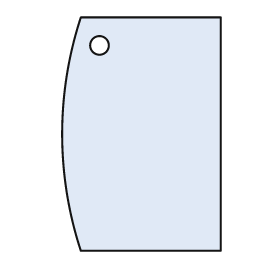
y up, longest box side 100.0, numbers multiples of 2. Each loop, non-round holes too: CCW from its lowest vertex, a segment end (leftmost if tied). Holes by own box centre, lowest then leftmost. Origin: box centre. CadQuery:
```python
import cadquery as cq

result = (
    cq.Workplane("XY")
    .moveTo(-26.0, -50.0)
    .lineTo(34.0, -50.0)
    .lineTo(34.0, 50.0)
    .lineTo(-26.0, 50.0)
    .threePointArc((-34.0, 0.0), (-26.0, -50.0))
    .close()
    .moveTo(-18.0, 38.0)
    .circle(4.0)
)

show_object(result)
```